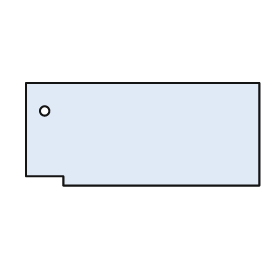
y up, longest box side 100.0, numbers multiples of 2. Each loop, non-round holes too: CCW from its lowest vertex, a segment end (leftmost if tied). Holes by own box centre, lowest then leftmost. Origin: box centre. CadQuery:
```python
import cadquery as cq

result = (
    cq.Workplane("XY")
    .moveTo(-34.0, -22.0)
    .lineTo(50.0, -22.0)
    .lineTo(50.0, 22.0)
    .lineTo(-50.0, 22.0)
    .lineTo(-50.0, -18.0)
    .lineTo(-34.0, -18.0)
    .close()
    .moveTo(-42.0, 10.0)
    .circle(2.0)
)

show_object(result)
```